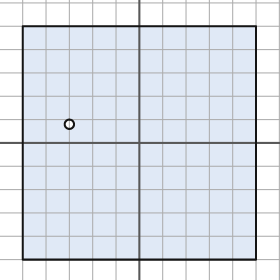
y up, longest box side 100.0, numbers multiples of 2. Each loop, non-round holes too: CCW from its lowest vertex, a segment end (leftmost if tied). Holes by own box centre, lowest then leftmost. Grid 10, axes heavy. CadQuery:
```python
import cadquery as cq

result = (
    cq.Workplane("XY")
    .moveTo(-50.0, -50.0)
    .lineTo(50.0, -50.0)
    .lineTo(50.0, 50.0)
    .lineTo(-50.0, 50.0)
    .close()
    .moveTo(-30.0, 8.0)
    .circle(2.0)
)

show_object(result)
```